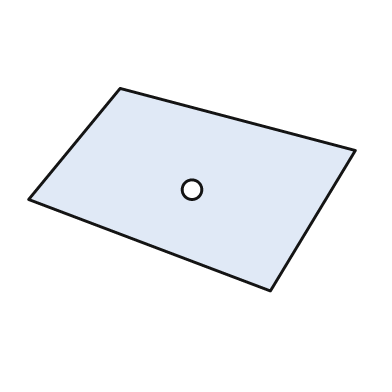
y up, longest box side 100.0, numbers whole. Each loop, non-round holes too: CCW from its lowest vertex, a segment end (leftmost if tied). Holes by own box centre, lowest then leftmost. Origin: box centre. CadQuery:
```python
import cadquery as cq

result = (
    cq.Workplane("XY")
    .moveTo(24.0, -31.0)
    .lineTo(50.0, 12.0)
    .lineTo(-22.0, 31.0)
    .lineTo(-50.0, -3.0)
    .close()
    .moveTo(0.0, 0.0)
    .circle(3.0)
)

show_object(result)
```